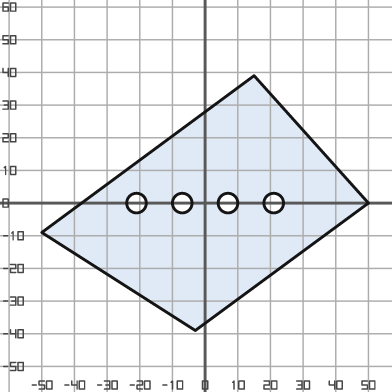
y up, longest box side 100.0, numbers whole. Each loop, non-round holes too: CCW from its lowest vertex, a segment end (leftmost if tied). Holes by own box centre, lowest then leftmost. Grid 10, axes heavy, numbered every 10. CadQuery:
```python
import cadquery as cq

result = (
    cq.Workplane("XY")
    .moveTo(-3.0, -39.0)
    .lineTo(50.0, 0.0)
    .lineTo(15.0, 39.0)
    .lineTo(-50.0, -9.0)
    .close()
    .moveTo(-21.0, 0.0)
    .circle(3.0)
    .moveTo(-7.0, 0.0)
    .circle(3.0)
    .moveTo(7.0, 0.0)
    .circle(3.0)
    .moveTo(21.0, 0.0)
    .circle(3.0)
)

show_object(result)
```